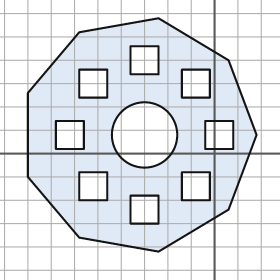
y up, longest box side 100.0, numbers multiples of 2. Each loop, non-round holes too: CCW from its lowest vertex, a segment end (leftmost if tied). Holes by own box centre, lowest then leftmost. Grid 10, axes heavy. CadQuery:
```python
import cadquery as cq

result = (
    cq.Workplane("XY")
    .moveTo(-24.0, -42.0)
    .lineTo(6.0, -24.0)
    .lineTo(18.0, 8.0)
    .lineTo(6.0, 40.0)
    .lineTo(-24.0, 58.0)
    .lineTo(-58.0, 52.0)
    .lineTo(-80.0, 26.0)
    .lineTo(-80.0, -10.0)
    .lineTo(-58.0, -36.0)
    .close()
    .moveTo(-36.0, -30.0)
    .lineTo(-24.0, -30.0)
    .lineTo(-24.0, -18.0)
    .lineTo(-36.0, -18.0)
    .close()
    .moveTo(-58.0, -20.0)
    .lineTo(-46.0, -20.0)
    .lineTo(-46.0, -8.0)
    .lineTo(-58.0, -8.0)
    .close()
    .moveTo(-14.0, -20.0)
    .lineTo(-2.0, -20.0)
    .lineTo(-2.0, -8.0)
    .lineTo(-14.0, -8.0)
    .close()
    .moveTo(-68.0, 2.0)
    .lineTo(-56.0, 2.0)
    .lineTo(-56.0, 14.0)
    .lineTo(-68.0, 14.0)
    .close()
    .moveTo(-30.0, 8.0)
    .circle(14.0)
    .moveTo(-4.0, 2.0)
    .lineTo(8.0, 2.0)
    .lineTo(8.0, 14.0)
    .lineTo(-4.0, 14.0)
    .close()
    .moveTo(-58.0, 24.0)
    .lineTo(-46.0, 24.0)
    .lineTo(-46.0, 36.0)
    .lineTo(-58.0, 36.0)
    .close()
    .moveTo(-14.0, 24.0)
    .lineTo(-2.0, 24.0)
    .lineTo(-2.0, 36.0)
    .lineTo(-14.0, 36.0)
    .close()
    .moveTo(-36.0, 34.0)
    .lineTo(-24.0, 34.0)
    .lineTo(-24.0, 46.0)
    .lineTo(-36.0, 46.0)
    .close()
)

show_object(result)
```